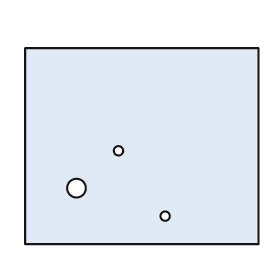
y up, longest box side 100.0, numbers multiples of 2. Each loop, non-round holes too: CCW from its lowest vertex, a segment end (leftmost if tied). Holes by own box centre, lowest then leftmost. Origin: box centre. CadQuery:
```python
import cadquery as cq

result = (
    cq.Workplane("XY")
    .moveTo(-50.0, -42.0)
    .lineTo(50.0, -42.0)
    .lineTo(50.0, 42.0)
    .lineTo(-50.0, 42.0)
    .close()
    .moveTo(10.0, -30.0)
    .circle(2.0)
    .moveTo(-28.0, -18.0)
    .circle(4.0)
    .moveTo(-10.0, -2.0)
    .circle(2.0)
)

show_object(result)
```